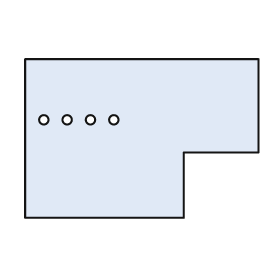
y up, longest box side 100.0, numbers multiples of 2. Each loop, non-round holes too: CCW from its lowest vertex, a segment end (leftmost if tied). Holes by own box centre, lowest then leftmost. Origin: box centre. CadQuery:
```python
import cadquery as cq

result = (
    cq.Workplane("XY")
    .moveTo(-50.0, -34.0)
    .lineTo(18.0, -34.0)
    .lineTo(18.0, -6.0)
    .lineTo(50.0, -6.0)
    .lineTo(50.0, 34.0)
    .lineTo(-50.0, 34.0)
    .close()
    .moveTo(-42.0, 8.0)
    .circle(2.0)
    .moveTo(-32.0, 8.0)
    .circle(2.0)
    .moveTo(-22.0, 8.0)
    .circle(2.0)
    .moveTo(-12.0, 8.0)
    .circle(2.0)
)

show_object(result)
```